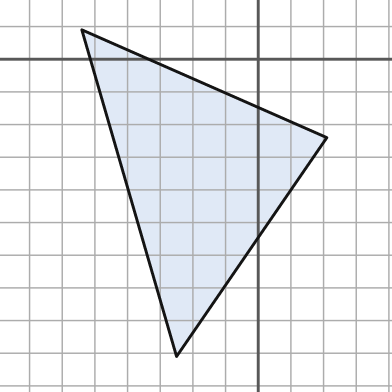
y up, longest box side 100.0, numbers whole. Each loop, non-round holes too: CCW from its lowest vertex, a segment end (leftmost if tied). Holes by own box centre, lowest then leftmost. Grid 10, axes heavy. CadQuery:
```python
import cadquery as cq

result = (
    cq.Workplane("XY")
    .moveTo(-25.0, -91.0)
    .lineTo(21.0, -24.0)
    .lineTo(-54.0, 9.0)
    .close()
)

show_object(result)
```